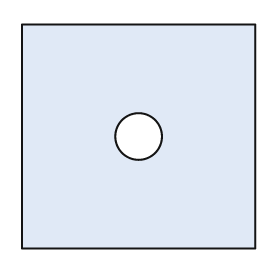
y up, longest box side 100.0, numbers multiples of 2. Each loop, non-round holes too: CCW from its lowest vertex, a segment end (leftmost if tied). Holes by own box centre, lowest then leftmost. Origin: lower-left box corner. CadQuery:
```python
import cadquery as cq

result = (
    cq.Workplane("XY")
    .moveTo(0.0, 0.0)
    .lineTo(100.0, 0.0)
    .lineTo(100.0, 96.0)
    .lineTo(0.0, 96.0)
    .close()
    .moveTo(50.0, 48.0)
    .circle(10.0)
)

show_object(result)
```